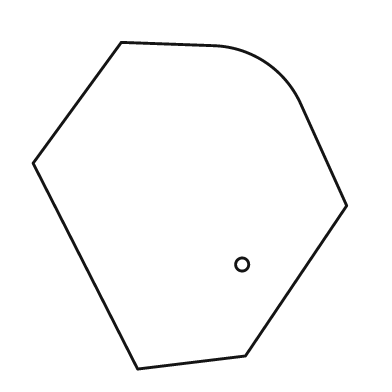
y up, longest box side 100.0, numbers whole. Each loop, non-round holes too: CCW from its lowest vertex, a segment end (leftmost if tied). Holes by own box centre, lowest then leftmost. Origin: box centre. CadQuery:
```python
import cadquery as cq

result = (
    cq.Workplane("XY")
    .moveTo(-16.0, -50.0)
    .lineTo(17.0, -46.0)
    .lineTo(48.0, 0.0)
    .lineTo(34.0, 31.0)
    .threePointArc((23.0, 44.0), (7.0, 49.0))
    .lineTo(-21.0, 50.0)
    .lineTo(-48.0, 13.0)
    .close()
    .moveTo(16.0, -18.0)
    .circle(2.0)
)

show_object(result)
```